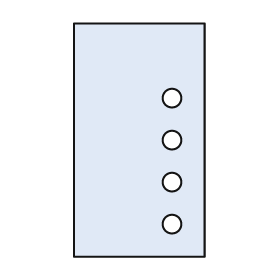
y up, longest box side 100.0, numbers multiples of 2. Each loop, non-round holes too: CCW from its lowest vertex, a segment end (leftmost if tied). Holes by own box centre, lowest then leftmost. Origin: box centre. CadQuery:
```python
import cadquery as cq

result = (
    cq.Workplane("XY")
    .moveTo(-28.0, -50.0)
    .lineTo(28.0, -50.0)
    .lineTo(28.0, 50.0)
    .lineTo(-28.0, 50.0)
    .close()
    .moveTo(14.0, -36.0)
    .circle(4.0)
    .moveTo(14.0, -18.0)
    .circle(4.0)
    .moveTo(14.0, 0.0)
    .circle(4.0)
    .moveTo(14.0, 18.0)
    .circle(4.0)
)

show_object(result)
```